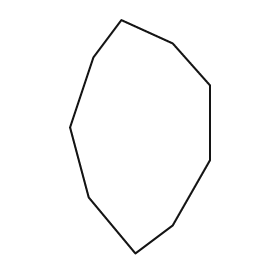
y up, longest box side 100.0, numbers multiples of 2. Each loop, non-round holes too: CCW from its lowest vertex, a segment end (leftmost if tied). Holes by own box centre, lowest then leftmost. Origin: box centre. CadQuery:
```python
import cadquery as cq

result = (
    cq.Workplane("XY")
    .moveTo(-2.0, -50.0)
    .lineTo(14.0, -38.0)
    .lineTo(30.0, -10.0)
    .lineTo(30.0, 22.0)
    .lineTo(14.0, 40.0)
    .lineTo(-8.0, 50.0)
    .lineTo(-20.0, 34.0)
    .lineTo(-30.0, 4.0)
    .lineTo(-22.0, -26.0)
    .close()
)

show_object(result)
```